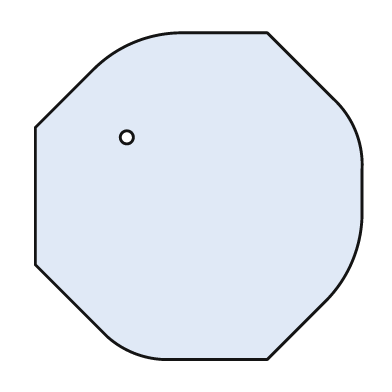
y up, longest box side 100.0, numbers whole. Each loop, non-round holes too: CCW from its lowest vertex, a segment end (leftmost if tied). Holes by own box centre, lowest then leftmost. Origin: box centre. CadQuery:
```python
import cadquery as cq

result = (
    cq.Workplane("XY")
    .moveTo(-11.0, -50.0)
    .lineTo(21.0, -50.0)
    .lineTo(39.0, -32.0)
    .threePointArc((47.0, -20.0), (50.0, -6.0))
    .lineTo(50.0, 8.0)
    .threePointArc((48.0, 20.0), (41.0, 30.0))
    .lineTo(21.0, 50.0)
    .lineTo(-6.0, 50.0)
    .threePointArc((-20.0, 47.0), (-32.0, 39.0))
    .lineTo(-50.0, 21.0)
    .lineTo(-50.0, -21.0)
    .lineTo(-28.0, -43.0)
    .threePointArc((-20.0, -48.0), (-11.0, -50.0))
    .close()
    .moveTo(-22.0, 18.0)
    .circle(2.0)
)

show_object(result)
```